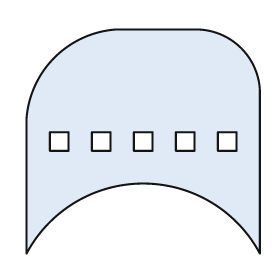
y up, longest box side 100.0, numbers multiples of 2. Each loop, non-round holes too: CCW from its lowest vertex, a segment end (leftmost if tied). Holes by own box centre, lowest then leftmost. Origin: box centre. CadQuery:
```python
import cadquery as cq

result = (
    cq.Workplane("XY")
    .moveTo(-50.0, -48.0)
    .threePointArc((0.0, -18.0), (50.0, -48.0))
    .lineTo(50.0, 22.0)
    .threePointArc((42.0, 40.0), (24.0, 48.0))
    .lineTo(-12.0, 48.0)
    .threePointArc((-38.0, 36.0), (-50.0, 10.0))
    .close()
    .moveTo(-40.0, -4.0)
    .lineTo(-32.0, -4.0)
    .lineTo(-32.0, 4.0)
    .lineTo(-40.0, 4.0)
    .close()
    .moveTo(-22.0, -4.0)
    .lineTo(-14.0, -4.0)
    .lineTo(-14.0, 4.0)
    .lineTo(-22.0, 4.0)
    .close()
    .moveTo(-4.0, -4.0)
    .lineTo(4.0, -4.0)
    .lineTo(4.0, 4.0)
    .lineTo(-4.0, 4.0)
    .close()
    .moveTo(14.0, -4.0)
    .lineTo(22.0, -4.0)
    .lineTo(22.0, 4.0)
    .lineTo(14.0, 4.0)
    .close()
    .moveTo(32.0, -4.0)
    .lineTo(40.0, -4.0)
    .lineTo(40.0, 4.0)
    .lineTo(32.0, 4.0)
    .close()
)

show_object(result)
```